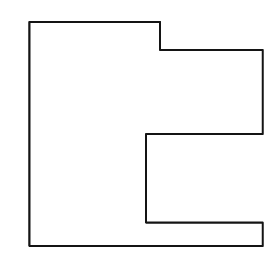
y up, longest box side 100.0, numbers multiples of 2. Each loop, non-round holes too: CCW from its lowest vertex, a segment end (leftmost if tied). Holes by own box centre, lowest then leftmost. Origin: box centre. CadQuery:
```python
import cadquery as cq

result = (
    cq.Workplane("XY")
    .moveTo(-50.0, -48.0)
    .lineTo(50.0, -48.0)
    .lineTo(50.0, -38.0)
    .lineTo(0.0, -38.0)
    .lineTo(0.0, 0.0)
    .lineTo(50.0, 0.0)
    .lineTo(50.0, 36.0)
    .lineTo(6.0, 36.0)
    .lineTo(6.0, 48.0)
    .lineTo(-50.0, 48.0)
    .close()
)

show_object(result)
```